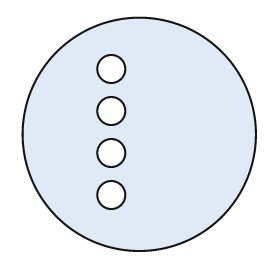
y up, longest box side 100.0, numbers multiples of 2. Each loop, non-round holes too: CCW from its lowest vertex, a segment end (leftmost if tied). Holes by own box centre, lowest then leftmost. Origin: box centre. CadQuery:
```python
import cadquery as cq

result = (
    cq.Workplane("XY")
    .moveTo(0.0, 0.0)
    .circle(50.0)
    .moveTo(-12.0, -26.0)
    .circle(6.0)
    .moveTo(-12.0, -8.0)
    .circle(6.0)
    .moveTo(-12.0, 10.0)
    .circle(6.0)
    .moveTo(-12.0, 28.0)
    .circle(6.0)
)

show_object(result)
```